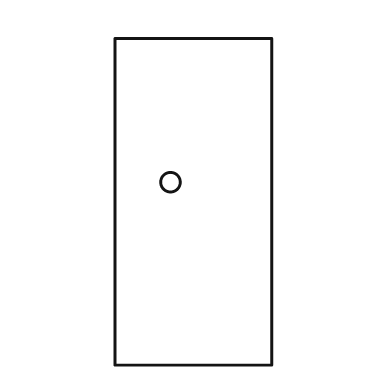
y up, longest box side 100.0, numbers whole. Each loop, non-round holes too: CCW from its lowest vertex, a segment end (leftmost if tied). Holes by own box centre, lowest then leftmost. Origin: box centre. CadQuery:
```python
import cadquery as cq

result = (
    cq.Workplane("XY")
    .moveTo(-24.0, -50.0)
    .lineTo(24.0, -50.0)
    .lineTo(24.0, 50.0)
    .lineTo(-24.0, 50.0)
    .close()
    .moveTo(-7.0, 6.0)
    .circle(3.0)
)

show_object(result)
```